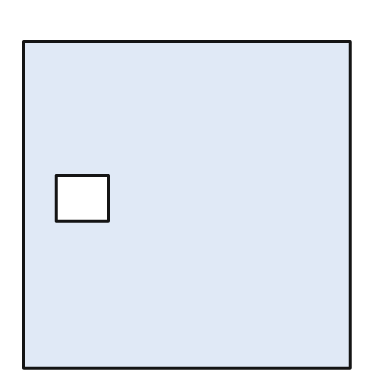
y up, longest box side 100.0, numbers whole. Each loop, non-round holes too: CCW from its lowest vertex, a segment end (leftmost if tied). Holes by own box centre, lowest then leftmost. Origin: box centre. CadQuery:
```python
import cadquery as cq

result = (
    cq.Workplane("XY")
    .moveTo(-50.0, -50.0)
    .lineTo(50.0, -50.0)
    .lineTo(50.0, 50.0)
    .lineTo(-50.0, 50.0)
    .close()
    .moveTo(-40.0, -5.0)
    .lineTo(-24.0, -5.0)
    .lineTo(-24.0, 9.0)
    .lineTo(-40.0, 9.0)
    .close()
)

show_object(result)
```